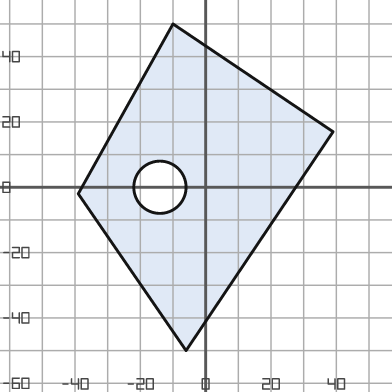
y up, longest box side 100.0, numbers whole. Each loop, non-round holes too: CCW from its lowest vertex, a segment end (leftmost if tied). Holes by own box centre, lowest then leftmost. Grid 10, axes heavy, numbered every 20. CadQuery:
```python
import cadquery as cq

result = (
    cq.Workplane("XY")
    .moveTo(-6.0, -50.0)
    .lineTo(39.0, 17.0)
    .lineTo(-10.0, 50.0)
    .lineTo(-39.0, -2.0)
    .close()
    .moveTo(-14.0, 0.0)
    .circle(8.0)
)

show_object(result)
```